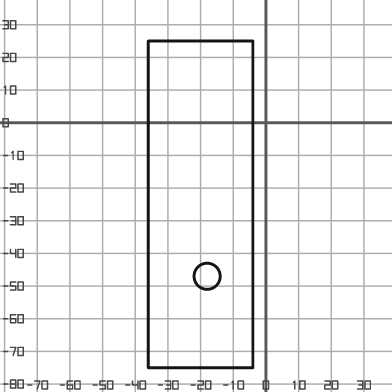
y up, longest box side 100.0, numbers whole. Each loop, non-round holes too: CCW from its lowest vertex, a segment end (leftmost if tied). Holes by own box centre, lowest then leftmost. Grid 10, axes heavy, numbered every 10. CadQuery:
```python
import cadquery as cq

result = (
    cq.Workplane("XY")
    .moveTo(-36.0, -75.0)
    .lineTo(-4.0, -75.0)
    .lineTo(-4.0, 25.0)
    .lineTo(-36.0, 25.0)
    .close()
    .moveTo(-18.0, -47.0)
    .circle(4.0)
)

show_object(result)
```